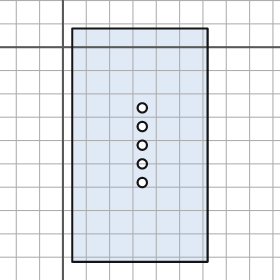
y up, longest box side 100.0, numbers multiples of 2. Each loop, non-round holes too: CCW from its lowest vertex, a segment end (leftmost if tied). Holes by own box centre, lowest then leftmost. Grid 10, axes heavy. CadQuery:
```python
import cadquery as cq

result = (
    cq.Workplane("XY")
    .moveTo(4.0, -92.0)
    .lineTo(62.0, -92.0)
    .lineTo(62.0, 8.0)
    .lineTo(4.0, 8.0)
    .close()
    .moveTo(34.0, -58.0)
    .circle(2.0)
    .moveTo(34.0, -50.0)
    .circle(2.0)
    .moveTo(34.0, -42.0)
    .circle(2.0)
    .moveTo(34.0, -34.0)
    .circle(2.0)
    .moveTo(34.0, -26.0)
    .circle(2.0)
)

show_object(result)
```